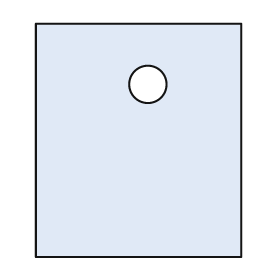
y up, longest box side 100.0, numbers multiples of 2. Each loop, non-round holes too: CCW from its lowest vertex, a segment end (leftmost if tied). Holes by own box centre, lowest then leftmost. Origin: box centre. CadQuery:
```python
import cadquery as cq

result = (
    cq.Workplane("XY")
    .moveTo(-44.0, -50.0)
    .lineTo(44.0, -50.0)
    .lineTo(44.0, 50.0)
    .lineTo(-44.0, 50.0)
    .close()
    .moveTo(4.0, 24.0)
    .circle(8.0)
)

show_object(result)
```